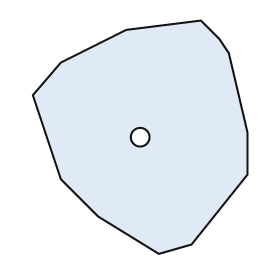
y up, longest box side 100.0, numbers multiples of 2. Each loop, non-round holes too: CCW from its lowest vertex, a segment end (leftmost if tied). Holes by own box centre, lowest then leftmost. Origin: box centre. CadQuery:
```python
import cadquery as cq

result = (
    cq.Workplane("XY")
    .moveTo(8.0, -50.0)
    .lineTo(22.0, -46.0)
    .lineTo(46.0, -16.0)
    .lineTo(46.0, 2.0)
    .lineTo(38.0, 36.0)
    .lineTo(34.0, 42.0)
    .lineTo(26.0, 50.0)
    .lineTo(-6.0, 46.0)
    .lineTo(-34.0, 32.0)
    .lineTo(-46.0, 18.0)
    .lineTo(-34.0, -18.0)
    .lineTo(-18.0, -34.0)
    .close()
    .moveTo(0.0, 0.0)
    .circle(4.0)
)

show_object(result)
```